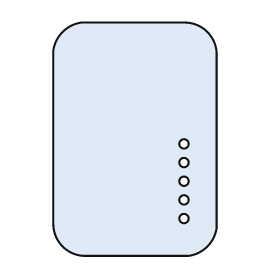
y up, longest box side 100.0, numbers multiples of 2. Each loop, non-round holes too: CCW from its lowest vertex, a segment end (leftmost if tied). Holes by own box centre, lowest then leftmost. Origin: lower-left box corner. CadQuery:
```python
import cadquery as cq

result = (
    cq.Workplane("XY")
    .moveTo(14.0, 0.0)
    .lineTo(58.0, 0.0)
    .threePointArc((66.0, 4.0), (70.0, 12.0))
    .lineTo(70.0, 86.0)
    .threePointArc((66.0, 96.0), (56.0, 100.0))
    .lineTo(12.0, 100.0)
    .threePointArc((4.0, 96.0), (0.0, 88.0))
    .lineTo(0.0, 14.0)
    .threePointArc((4.0, 4.0), (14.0, 0.0))
    .close()
    .moveTo(56.0, 16.0)
    .circle(2.0)
    .moveTo(56.0, 24.0)
    .circle(2.0)
    .moveTo(56.0, 32.0)
    .circle(2.0)
    .moveTo(56.0, 40.0)
    .circle(2.0)
    .moveTo(56.0, 48.0)
    .circle(2.0)
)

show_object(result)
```